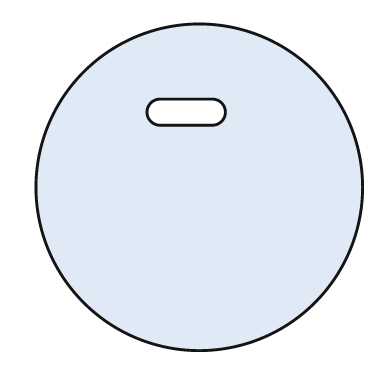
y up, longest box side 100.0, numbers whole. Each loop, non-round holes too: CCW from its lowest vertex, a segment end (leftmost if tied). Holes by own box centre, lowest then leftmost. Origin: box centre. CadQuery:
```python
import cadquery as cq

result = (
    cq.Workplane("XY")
    .moveTo(0.0, 0.0)
    .circle(50.0)
    .moveTo(-12.0, 19.0)
    .lineTo(4.0, 19.0)
    .threePointArc((8.0, 23.0), (4.0, 27.0))
    .lineTo(-12.0, 27.0)
    .threePointArc((-16.0, 23.0), (-12.0, 19.0))
    .close()
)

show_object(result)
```